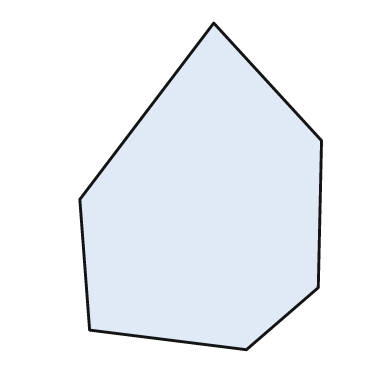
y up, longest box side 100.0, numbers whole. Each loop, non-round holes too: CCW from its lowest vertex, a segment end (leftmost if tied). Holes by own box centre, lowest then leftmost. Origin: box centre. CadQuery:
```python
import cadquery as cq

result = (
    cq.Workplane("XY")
    .moveTo(14.0, -50.0)
    .lineTo(36.0, -31.0)
    .lineTo(37.0, 14.0)
    .lineTo(4.0, 50.0)
    .lineTo(-37.0, -4.0)
    .lineTo(-34.0, -44.0)
    .close()
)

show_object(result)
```